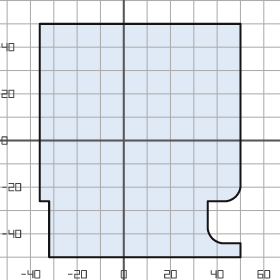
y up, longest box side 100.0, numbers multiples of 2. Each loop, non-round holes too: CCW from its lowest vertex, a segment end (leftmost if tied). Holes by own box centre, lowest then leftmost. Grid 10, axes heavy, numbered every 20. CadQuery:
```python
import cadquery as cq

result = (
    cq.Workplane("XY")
    .moveTo(-32.0, -50.0)
    .lineTo(50.0, -50.0)
    .lineTo(50.0, -44.0)
    .lineTo(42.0, -44.0)
    .threePointArc((38.0, -42.0), (36.0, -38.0))
    .lineTo(36.0, -26.0)
    .lineTo(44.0, -26.0)
    .threePointArc((48.0, -24.0), (50.0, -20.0))
    .lineTo(50.0, 50.0)
    .lineTo(-36.0, 50.0)
    .lineTo(-36.0, -26.0)
    .lineTo(-32.0, -26.0)
    .close()
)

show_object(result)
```